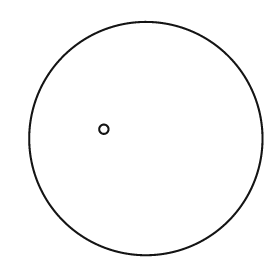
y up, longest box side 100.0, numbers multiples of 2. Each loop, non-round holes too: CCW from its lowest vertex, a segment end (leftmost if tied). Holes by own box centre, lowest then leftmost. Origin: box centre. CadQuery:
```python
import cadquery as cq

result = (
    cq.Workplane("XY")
    .moveTo(0.0, 0.0)
    .circle(50.0)
    .moveTo(-18.0, 4.0)
    .circle(2.0)
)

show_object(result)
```